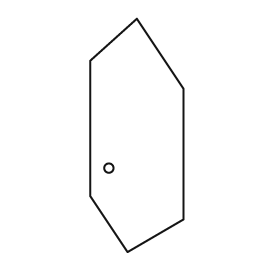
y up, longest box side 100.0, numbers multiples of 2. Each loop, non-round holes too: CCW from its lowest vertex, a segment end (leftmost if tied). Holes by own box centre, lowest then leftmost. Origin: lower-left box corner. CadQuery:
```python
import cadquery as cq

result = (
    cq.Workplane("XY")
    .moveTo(16.0, 0.0)
    .lineTo(40.0, 14.0)
    .lineTo(40.0, 70.0)
    .lineTo(20.0, 100.0)
    .lineTo(0.0, 82.0)
    .lineTo(0.0, 24.0)
    .close()
    .moveTo(8.0, 36.0)
    .circle(2.0)
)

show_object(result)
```